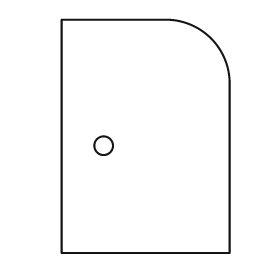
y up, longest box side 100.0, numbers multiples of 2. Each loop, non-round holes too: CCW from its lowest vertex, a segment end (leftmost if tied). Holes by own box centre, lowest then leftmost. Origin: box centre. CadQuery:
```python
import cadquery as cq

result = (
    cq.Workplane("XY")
    .moveTo(-36.0, -50.0)
    .lineTo(36.0, -50.0)
    .lineTo(36.0, 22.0)
    .threePointArc((28.0, 42.0), (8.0, 50.0))
    .lineTo(-36.0, 50.0)
    .close()
    .moveTo(-18.0, -4.0)
    .circle(4.0)
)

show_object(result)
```